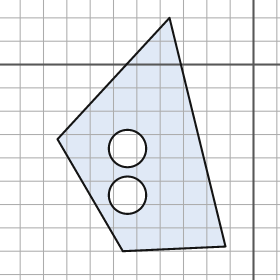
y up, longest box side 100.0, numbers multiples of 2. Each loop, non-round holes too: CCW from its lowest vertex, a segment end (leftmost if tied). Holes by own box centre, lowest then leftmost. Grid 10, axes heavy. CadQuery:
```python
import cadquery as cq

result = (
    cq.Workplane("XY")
    .moveTo(-56.0, -80.0)
    .lineTo(-12.0, -78.0)
    .lineTo(-36.0, 20.0)
    .lineTo(-84.0, -32.0)
    .close()
    .moveTo(-54.0, -56.0)
    .circle(8.0)
    .moveTo(-54.0, -36.0)
    .circle(8.0)
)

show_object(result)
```